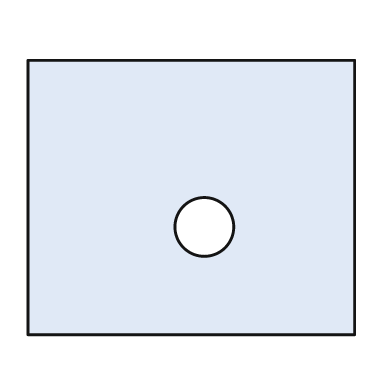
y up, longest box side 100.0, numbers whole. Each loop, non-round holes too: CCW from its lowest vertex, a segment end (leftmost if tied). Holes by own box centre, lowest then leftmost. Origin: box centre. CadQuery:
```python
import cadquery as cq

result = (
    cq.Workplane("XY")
    .moveTo(-50.0, -42.0)
    .lineTo(50.0, -42.0)
    .lineTo(50.0, 42.0)
    .lineTo(-50.0, 42.0)
    .close()
    .moveTo(4.0, -9.0)
    .circle(9.0)
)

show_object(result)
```